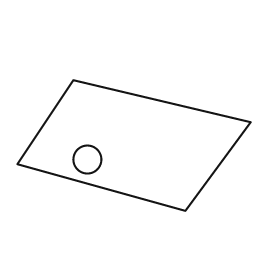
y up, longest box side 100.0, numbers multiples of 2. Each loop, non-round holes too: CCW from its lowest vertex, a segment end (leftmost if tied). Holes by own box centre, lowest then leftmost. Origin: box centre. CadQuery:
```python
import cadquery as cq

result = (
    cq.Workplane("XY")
    .moveTo(22.0, -28.0)
    .lineTo(50.0, 10.0)
    .lineTo(-26.0, 28.0)
    .lineTo(-50.0, -8.0)
    .close()
    .moveTo(-20.0, -6.0)
    .circle(6.0)
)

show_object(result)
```